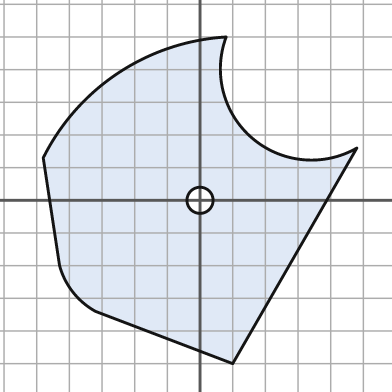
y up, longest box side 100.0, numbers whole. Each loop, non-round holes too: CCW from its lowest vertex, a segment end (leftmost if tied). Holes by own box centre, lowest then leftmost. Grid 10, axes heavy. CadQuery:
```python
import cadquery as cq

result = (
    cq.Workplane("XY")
    .moveTo(10.0, -50.0)
    .lineTo(48.0, 16.0)
    .threePointArc((16.0, 19.0), (8.0, 50.0))
    .threePointArc((-25.0, 39.0), (-48.0, 13.0))
    .lineTo(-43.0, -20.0)
    .threePointArc((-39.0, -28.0), (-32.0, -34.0))
    .close()
    .moveTo(0.0, 0.0)
    .circle(4.0)
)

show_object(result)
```